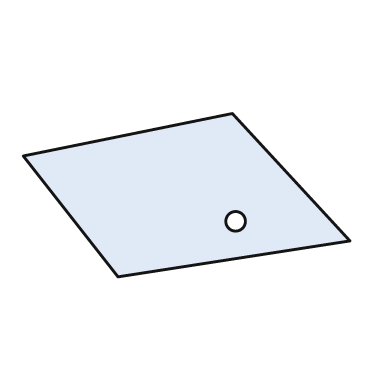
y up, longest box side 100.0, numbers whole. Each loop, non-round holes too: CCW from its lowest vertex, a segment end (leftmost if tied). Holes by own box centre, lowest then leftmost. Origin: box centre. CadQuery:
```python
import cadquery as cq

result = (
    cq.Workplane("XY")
    .moveTo(-21.0, -25.0)
    .lineTo(50.0, -14.0)
    .lineTo(14.0, 25.0)
    .lineTo(-50.0, 12.0)
    .close()
    .moveTo(15.0, -8.0)
    .circle(3.0)
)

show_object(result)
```